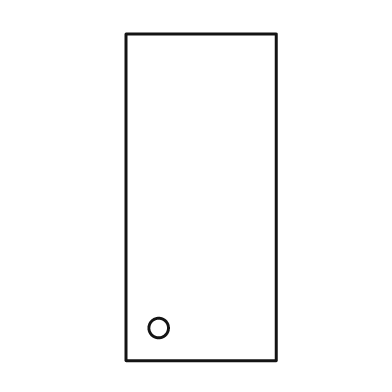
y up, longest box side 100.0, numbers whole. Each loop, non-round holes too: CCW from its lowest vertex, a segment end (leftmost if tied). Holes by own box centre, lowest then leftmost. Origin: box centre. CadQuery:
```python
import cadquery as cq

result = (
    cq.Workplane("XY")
    .moveTo(-23.0, -50.0)
    .lineTo(23.0, -50.0)
    .lineTo(23.0, 50.0)
    .lineTo(-23.0, 50.0)
    .close()
    .moveTo(-13.0, -40.0)
    .circle(3.0)
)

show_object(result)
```